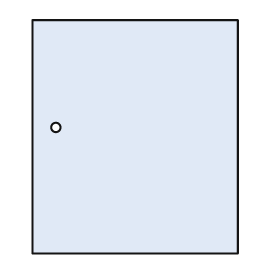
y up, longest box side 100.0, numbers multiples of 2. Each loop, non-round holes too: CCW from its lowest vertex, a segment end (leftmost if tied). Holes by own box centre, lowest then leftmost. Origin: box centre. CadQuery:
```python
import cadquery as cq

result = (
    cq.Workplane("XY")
    .moveTo(-44.0, -50.0)
    .lineTo(44.0, -50.0)
    .lineTo(44.0, 50.0)
    .lineTo(-44.0, 50.0)
    .close()
    .moveTo(-34.0, 4.0)
    .circle(2.0)
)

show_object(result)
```